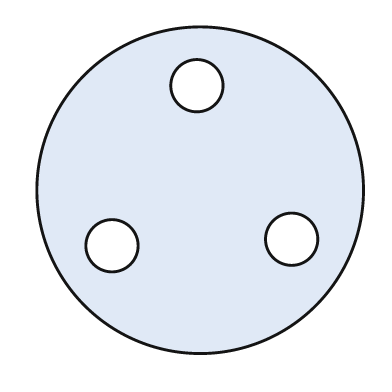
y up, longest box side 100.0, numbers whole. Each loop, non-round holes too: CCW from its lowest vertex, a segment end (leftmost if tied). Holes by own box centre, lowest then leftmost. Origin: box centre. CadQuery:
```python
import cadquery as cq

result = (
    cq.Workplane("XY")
    .moveTo(0.0, 0.0)
    .circle(50.0)
    .moveTo(-27.0, -17.0)
    .circle(8.0)
    .moveTo(28.0, -15.0)
    .circle(8.0)
    .moveTo(-1.0, 32.0)
    .circle(8.0)
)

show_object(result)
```